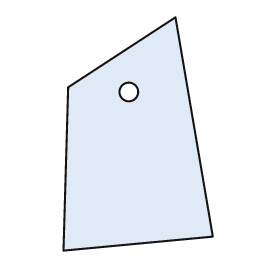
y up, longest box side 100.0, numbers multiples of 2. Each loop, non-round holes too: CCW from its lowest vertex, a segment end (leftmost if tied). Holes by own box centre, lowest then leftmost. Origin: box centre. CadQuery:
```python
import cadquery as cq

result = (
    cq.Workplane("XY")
    .moveTo(-32.0, -50.0)
    .lineTo(32.0, -44.0)
    .lineTo(16.0, 50.0)
    .lineTo(-30.0, 20.0)
    .close()
    .moveTo(-4.0, 18.0)
    .circle(4.0)
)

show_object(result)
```